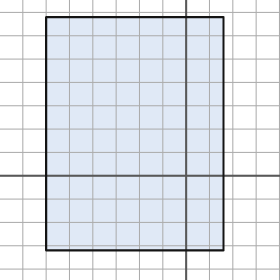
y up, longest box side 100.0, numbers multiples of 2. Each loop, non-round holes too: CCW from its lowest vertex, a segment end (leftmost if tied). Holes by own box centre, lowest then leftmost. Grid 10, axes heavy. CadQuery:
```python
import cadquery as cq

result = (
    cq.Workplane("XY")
    .moveTo(-60.0, -32.0)
    .lineTo(16.0, -32.0)
    .lineTo(16.0, 68.0)
    .lineTo(-60.0, 68.0)
    .close()
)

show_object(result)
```